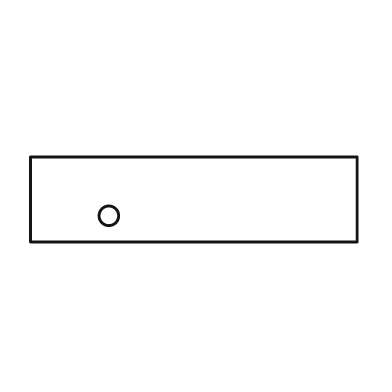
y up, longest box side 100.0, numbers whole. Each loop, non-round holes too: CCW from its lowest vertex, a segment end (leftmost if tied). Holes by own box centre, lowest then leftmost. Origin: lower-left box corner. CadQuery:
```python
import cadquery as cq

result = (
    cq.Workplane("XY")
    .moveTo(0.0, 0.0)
    .lineTo(100.0, 0.0)
    .lineTo(100.0, 26.0)
    .lineTo(0.0, 26.0)
    .close()
    .moveTo(24.0, 8.0)
    .circle(3.0)
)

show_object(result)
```